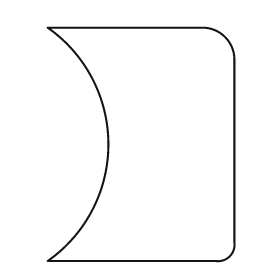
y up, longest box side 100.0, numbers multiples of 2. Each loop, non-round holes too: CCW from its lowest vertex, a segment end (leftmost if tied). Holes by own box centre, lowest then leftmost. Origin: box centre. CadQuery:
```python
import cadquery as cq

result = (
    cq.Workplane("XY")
    .moveTo(-40.0, -50.0)
    .lineTo(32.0, -50.0)
    .threePointArc((38.0, -48.0), (40.0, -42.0))
    .lineTo(40.0, 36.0)
    .threePointArc((36.0, 46.0), (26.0, 50.0))
    .lineTo(-40.0, 50.0)
    .threePointArc((-14.0, 0.0), (-40.0, -50.0))
    .close()
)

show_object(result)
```